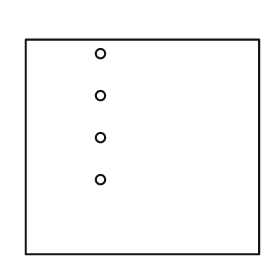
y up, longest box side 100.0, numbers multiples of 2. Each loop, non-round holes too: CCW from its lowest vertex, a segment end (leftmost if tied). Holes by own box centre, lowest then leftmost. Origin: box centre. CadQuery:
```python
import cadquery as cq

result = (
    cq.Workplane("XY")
    .moveTo(-50.0, -46.0)
    .lineTo(50.0, -46.0)
    .lineTo(50.0, 46.0)
    .lineTo(-50.0, 46.0)
    .close()
    .moveTo(-18.0, -14.0)
    .circle(2.0)
    .moveTo(-18.0, 4.0)
    .circle(2.0)
    .moveTo(-18.0, 22.0)
    .circle(2.0)
    .moveTo(-18.0, 40.0)
    .circle(2.0)
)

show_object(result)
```